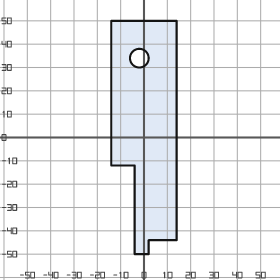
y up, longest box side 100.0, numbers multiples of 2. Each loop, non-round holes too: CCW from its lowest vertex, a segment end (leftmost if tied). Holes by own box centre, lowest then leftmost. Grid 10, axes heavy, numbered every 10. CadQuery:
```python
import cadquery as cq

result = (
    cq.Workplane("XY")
    .moveTo(-4.0, -50.0)
    .lineTo(2.0, -50.0)
    .lineTo(2.0, -44.0)
    .lineTo(14.0, -44.0)
    .lineTo(14.0, 50.0)
    .lineTo(-14.0, 50.0)
    .lineTo(-14.0, -12.0)
    .lineTo(-4.0, -12.0)
    .close()
    .moveTo(-2.0, 34.0)
    .circle(4.0)
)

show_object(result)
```